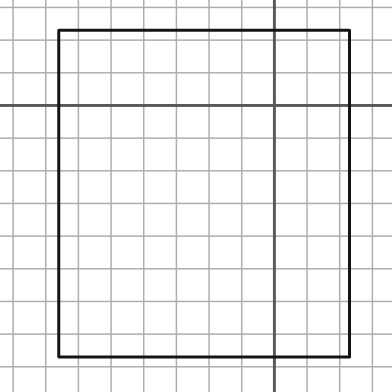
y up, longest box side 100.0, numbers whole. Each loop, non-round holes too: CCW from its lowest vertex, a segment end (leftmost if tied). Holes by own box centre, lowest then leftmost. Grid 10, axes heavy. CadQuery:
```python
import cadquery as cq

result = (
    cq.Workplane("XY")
    .moveTo(-66.0, -77.0)
    .lineTo(23.0, -77.0)
    .lineTo(23.0, 23.0)
    .lineTo(-66.0, 23.0)
    .close()
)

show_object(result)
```